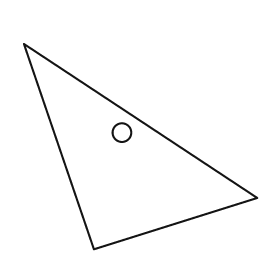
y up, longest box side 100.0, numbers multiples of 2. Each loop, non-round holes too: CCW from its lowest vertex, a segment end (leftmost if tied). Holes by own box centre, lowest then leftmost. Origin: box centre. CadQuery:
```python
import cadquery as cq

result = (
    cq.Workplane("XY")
    .moveTo(-20.0, -44.0)
    .lineTo(50.0, -22.0)
    .lineTo(-50.0, 44.0)
    .close()
    .moveTo(-8.0, 6.0)
    .circle(4.0)
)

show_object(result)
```